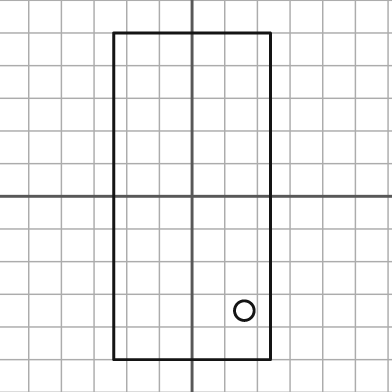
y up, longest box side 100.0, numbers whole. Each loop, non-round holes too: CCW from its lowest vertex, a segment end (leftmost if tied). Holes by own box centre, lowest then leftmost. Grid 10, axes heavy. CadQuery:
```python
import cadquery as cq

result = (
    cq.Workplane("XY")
    .moveTo(-24.0, -50.0)
    .lineTo(24.0, -50.0)
    .lineTo(24.0, 50.0)
    .lineTo(-24.0, 50.0)
    .close()
    .moveTo(16.0, -35.0)
    .circle(3.0)
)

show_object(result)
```